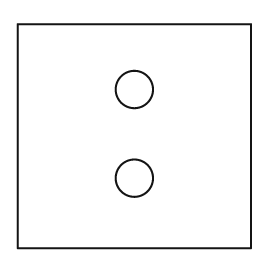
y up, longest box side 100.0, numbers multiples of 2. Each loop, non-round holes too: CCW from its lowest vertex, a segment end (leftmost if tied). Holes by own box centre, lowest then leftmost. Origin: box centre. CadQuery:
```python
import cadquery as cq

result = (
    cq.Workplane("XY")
    .moveTo(-50.0, -48.0)
    .lineTo(50.0, -48.0)
    .lineTo(50.0, 48.0)
    .lineTo(-50.0, 48.0)
    .close()
    .moveTo(0.0, -18.0)
    .circle(8.0)
    .moveTo(0.0, 20.0)
    .circle(8.0)
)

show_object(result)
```